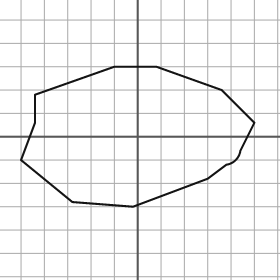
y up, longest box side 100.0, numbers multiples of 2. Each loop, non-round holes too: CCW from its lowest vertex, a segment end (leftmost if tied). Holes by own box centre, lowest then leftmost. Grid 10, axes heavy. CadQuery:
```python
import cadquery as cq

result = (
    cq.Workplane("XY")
    .moveTo(-2.0, -30.0)
    .lineTo(30.0, -18.0)
    .lineTo(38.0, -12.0)
    .threePointArc((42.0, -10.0), (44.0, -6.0))
    .lineTo(50.0, 6.0)
    .lineTo(36.0, 20.0)
    .lineTo(8.0, 30.0)
    .lineTo(-10.0, 30.0)
    .lineTo(-44.0, 18.0)
    .lineTo(-44.0, 6.0)
    .lineTo(-50.0, -10.0)
    .lineTo(-28.0, -28.0)
    .close()
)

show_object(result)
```